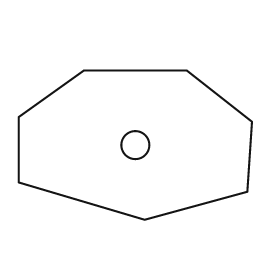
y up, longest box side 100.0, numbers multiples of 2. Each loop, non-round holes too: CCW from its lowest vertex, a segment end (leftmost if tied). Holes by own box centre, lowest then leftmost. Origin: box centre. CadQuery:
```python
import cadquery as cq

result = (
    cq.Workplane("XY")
    .moveTo(4.0, -32.0)
    .lineTo(48.0, -20.0)
    .lineTo(50.0, 10.0)
    .lineTo(22.0, 32.0)
    .lineTo(-22.0, 32.0)
    .lineTo(-50.0, 12.0)
    .lineTo(-50.0, -16.0)
    .close()
    .moveTo(0.0, 0.0)
    .circle(6.0)
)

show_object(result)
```